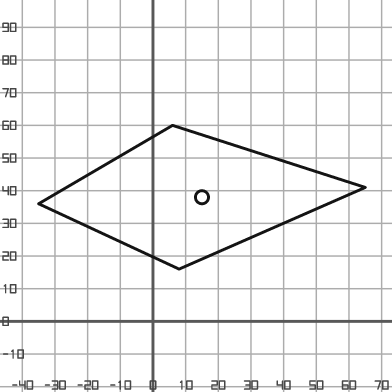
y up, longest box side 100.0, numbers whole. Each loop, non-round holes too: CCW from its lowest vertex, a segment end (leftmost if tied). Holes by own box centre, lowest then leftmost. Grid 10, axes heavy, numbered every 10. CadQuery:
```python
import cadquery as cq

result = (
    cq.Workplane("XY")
    .moveTo(8.0, 16.0)
    .lineTo(65.0, 41.0)
    .lineTo(6.0, 60.0)
    .lineTo(-35.0, 36.0)
    .close()
    .moveTo(15.0, 38.0)
    .circle(2.0)
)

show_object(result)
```